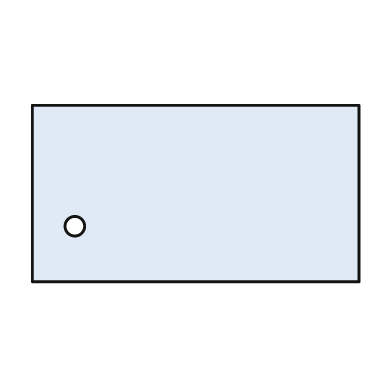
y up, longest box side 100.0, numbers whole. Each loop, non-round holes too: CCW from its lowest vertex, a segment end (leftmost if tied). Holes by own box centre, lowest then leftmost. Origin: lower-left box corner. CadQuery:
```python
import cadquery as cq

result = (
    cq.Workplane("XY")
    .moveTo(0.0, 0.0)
    .lineTo(100.0, 0.0)
    .lineTo(100.0, 54.0)
    .lineTo(0.0, 54.0)
    .close()
    .moveTo(13.0, 17.0)
    .circle(3.0)
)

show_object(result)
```